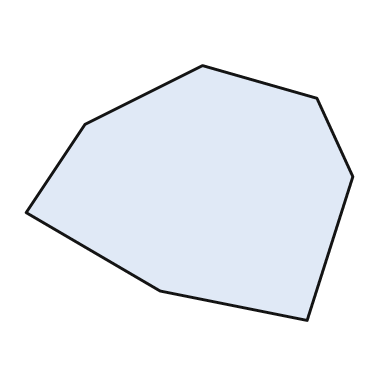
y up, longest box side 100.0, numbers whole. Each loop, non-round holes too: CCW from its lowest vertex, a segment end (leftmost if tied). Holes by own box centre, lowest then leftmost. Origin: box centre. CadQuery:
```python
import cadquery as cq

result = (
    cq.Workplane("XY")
    .moveTo(36.0, -39.0)
    .lineTo(50.0, 5.0)
    .lineTo(39.0, 29.0)
    .lineTo(4.0, 39.0)
    .lineTo(-32.0, 21.0)
    .lineTo(-50.0, -6.0)
    .lineTo(-9.0, -30.0)
    .close()
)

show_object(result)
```